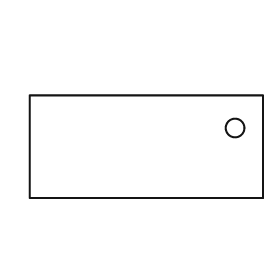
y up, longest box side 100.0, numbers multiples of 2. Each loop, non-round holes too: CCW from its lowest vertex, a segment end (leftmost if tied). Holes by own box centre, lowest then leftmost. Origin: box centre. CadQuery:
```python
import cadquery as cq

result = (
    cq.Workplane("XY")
    .moveTo(-50.0, -22.0)
    .lineTo(50.0, -22.0)
    .lineTo(50.0, 22.0)
    .lineTo(-50.0, 22.0)
    .close()
    .moveTo(38.0, 8.0)
    .circle(4.0)
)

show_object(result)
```